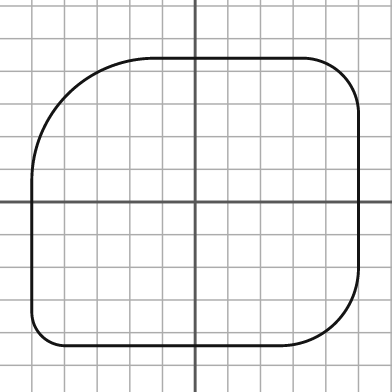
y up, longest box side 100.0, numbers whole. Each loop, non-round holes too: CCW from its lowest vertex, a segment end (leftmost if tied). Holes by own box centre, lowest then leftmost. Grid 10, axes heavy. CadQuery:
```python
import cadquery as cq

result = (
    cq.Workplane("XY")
    .moveTo(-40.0, -44.0)
    .lineTo(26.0, -44.0)
    .threePointArc((43.0, -37.0), (50.0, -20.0))
    .lineTo(50.0, 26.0)
    .threePointArc((45.0, 39.0), (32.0, 44.0))
    .lineTo(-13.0, 44.0)
    .threePointArc((-39.0, 33.0), (-50.0, 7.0))
    .lineTo(-50.0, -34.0)
    .threePointArc((-47.0, -41.0), (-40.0, -44.0))
    .close()
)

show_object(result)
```